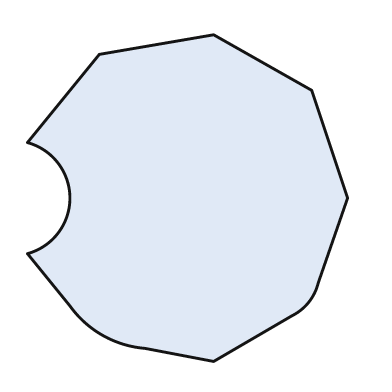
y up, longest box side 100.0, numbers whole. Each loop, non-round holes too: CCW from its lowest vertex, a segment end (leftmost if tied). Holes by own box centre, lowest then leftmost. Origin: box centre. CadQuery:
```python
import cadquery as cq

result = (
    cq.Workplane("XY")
    .moveTo(8.0, -50.0)
    .lineTo(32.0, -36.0)
    .threePointArc((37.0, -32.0), (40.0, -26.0))
    .lineTo(49.0, 0.0)
    .lineTo(38.0, 33.0)
    .lineTo(8.0, 50.0)
    .lineTo(-27.0, 44.0)
    .lineTo(-49.0, 17.0)
    .threePointArc((-36.0, 0.0), (-49.0, -17.0))
    .lineTo(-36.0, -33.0)
    .threePointArc((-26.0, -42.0), (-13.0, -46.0))
    .close()
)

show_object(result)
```